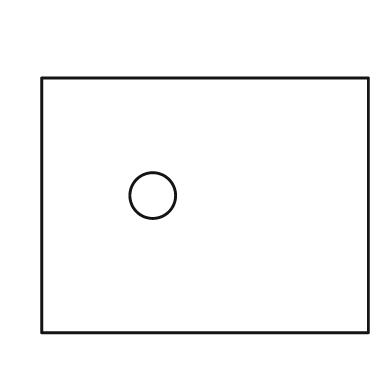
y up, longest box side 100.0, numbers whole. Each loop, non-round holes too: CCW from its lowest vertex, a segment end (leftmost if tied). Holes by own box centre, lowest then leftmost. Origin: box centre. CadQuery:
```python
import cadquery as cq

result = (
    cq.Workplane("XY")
    .moveTo(-50.0, -39.0)
    .lineTo(50.0, -39.0)
    .lineTo(50.0, 39.0)
    .lineTo(-50.0, 39.0)
    .close()
    .moveTo(-16.0, 3.0)
    .circle(7.0)
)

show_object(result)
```